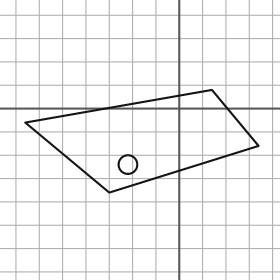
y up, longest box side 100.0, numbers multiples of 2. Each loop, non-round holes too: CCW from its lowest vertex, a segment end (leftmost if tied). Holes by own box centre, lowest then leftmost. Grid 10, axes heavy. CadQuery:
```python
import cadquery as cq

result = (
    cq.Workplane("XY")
    .moveTo(-30.0, -36.0)
    .lineTo(34.0, -16.0)
    .lineTo(14.0, 8.0)
    .lineTo(-66.0, -6.0)
    .close()
    .moveTo(-22.0, -24.0)
    .circle(4.0)
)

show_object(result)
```